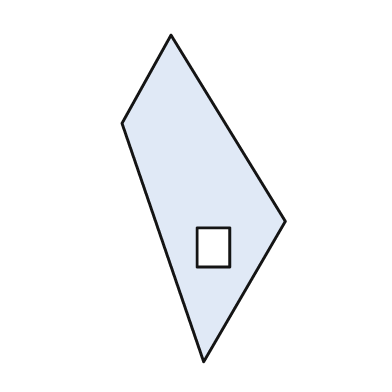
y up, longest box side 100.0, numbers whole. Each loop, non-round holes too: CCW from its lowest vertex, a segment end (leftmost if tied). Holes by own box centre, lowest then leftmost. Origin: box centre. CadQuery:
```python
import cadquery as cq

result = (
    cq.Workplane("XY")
    .moveTo(0.0, -50.0)
    .lineTo(25.0, -7.0)
    .lineTo(-10.0, 50.0)
    .lineTo(-25.0, 23.0)
    .close()
    .moveTo(-2.0, -21.0)
    .lineTo(8.0, -21.0)
    .lineTo(8.0, -9.0)
    .lineTo(-2.0, -9.0)
    .close()
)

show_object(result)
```